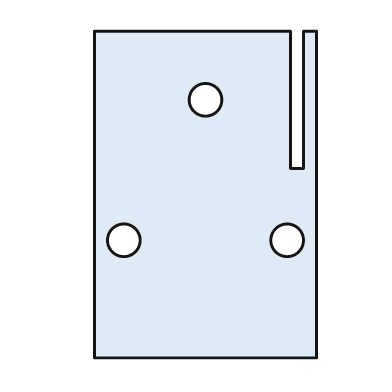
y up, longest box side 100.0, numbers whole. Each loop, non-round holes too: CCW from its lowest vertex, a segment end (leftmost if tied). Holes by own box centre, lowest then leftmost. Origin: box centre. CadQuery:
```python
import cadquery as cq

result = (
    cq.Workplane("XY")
    .moveTo(-34.0, -50.0)
    .lineTo(34.0, -50.0)
    .lineTo(34.0, 50.0)
    .lineTo(30.0, 50.0)
    .lineTo(30.0, 8.0)
    .lineTo(26.0, 8.0)
    .lineTo(26.0, 50.0)
    .lineTo(-34.0, 50.0)
    .close()
    .moveTo(-25.0, -14.0)
    .circle(5.0)
    .moveTo(25.0, -14.0)
    .circle(5.0)
    .moveTo(0.0, 29.0)
    .circle(5.0)
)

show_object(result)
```